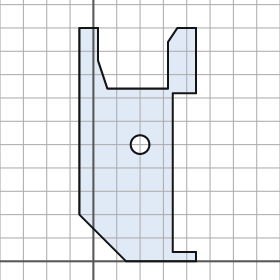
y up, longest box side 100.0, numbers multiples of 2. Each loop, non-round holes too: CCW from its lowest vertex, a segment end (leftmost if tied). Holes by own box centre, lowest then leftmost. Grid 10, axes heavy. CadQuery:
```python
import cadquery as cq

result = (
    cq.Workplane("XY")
    .moveTo(14.0, 0.0)
    .lineTo(44.0, 0.0)
    .lineTo(44.0, 4.0)
    .lineTo(34.0, 4.0)
    .lineTo(34.0, 72.0)
    .lineTo(44.0, 72.0)
    .lineTo(44.0, 100.0)
    .lineTo(36.0, 100.0)
    .lineTo(32.0, 94.0)
    .lineTo(32.0, 74.0)
    .lineTo(6.0, 74.0)
    .lineTo(2.0, 86.0)
    .lineTo(2.0, 100.0)
    .lineTo(-6.0, 100.0)
    .lineTo(-6.0, 20.0)
    .close()
    .moveTo(20.0, 50.0)
    .circle(4.0)
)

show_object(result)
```